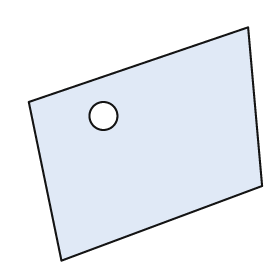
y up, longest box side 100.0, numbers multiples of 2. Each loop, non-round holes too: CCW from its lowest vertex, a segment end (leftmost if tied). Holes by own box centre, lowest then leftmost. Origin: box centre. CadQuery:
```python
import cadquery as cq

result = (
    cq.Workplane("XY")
    .moveTo(-36.0, -50.0)
    .lineTo(50.0, -18.0)
    .lineTo(44.0, 50.0)
    .lineTo(-50.0, 18.0)
    .close()
    .moveTo(-18.0, 12.0)
    .circle(6.0)
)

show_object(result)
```